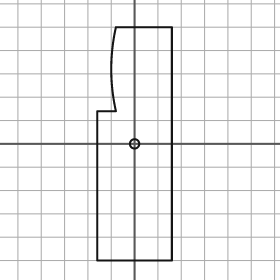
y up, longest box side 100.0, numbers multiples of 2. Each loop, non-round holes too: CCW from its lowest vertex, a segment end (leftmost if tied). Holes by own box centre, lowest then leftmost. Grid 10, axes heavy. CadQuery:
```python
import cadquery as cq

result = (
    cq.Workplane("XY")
    .moveTo(-16.0, -50.0)
    .lineTo(16.0, -50.0)
    .lineTo(16.0, 50.0)
    .lineTo(-8.0, 50.0)
    .threePointArc((-10.0, 32.0), (-8.0, 14.0))
    .lineTo(-16.0, 14.0)
    .close()
    .moveTo(0.0, 0.0)
    .circle(2.0)
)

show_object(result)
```